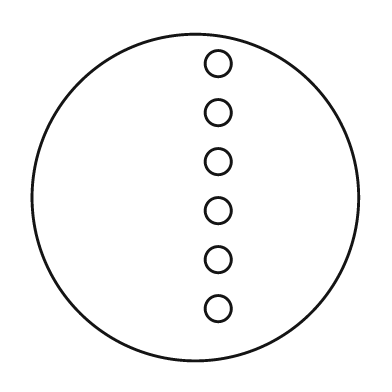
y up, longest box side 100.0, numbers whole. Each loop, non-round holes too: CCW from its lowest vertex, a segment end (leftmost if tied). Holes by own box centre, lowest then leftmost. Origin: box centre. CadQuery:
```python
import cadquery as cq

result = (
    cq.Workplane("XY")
    .moveTo(0.0, 0.0)
    .circle(50.0)
    .moveTo(7.0, -34.0)
    .circle(4.0)
    .moveTo(7.0, -19.0)
    .circle(4.0)
    .moveTo(7.0, -4.0)
    .circle(4.0)
    .moveTo(7.0, 11.0)
    .circle(4.0)
    .moveTo(7.0, 26.0)
    .circle(4.0)
    .moveTo(7.0, 41.0)
    .circle(4.0)
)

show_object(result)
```